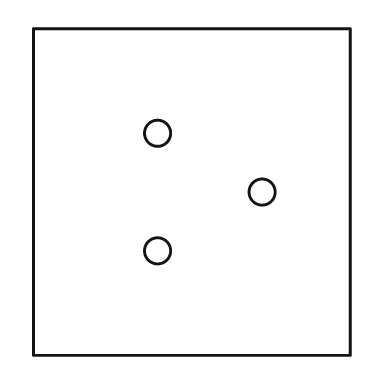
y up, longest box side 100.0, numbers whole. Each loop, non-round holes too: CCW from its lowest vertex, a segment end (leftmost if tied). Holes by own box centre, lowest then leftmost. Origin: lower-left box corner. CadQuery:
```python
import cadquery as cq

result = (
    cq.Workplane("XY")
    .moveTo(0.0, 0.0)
    .lineTo(97.0, 0.0)
    .lineTo(97.0, 100.0)
    .lineTo(0.0, 100.0)
    .close()
    .moveTo(38.0, 32.0)
    .circle(4.0)
    .moveTo(70.0, 50.0)
    .circle(4.0)
    .moveTo(38.0, 68.0)
    .circle(4.0)
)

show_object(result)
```